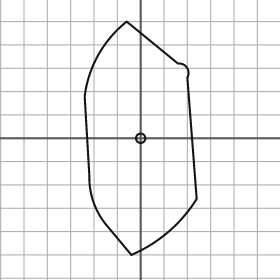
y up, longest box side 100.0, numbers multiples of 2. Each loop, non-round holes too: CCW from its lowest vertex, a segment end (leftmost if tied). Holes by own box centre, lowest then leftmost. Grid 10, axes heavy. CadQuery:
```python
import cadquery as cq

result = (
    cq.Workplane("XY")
    .moveTo(-4.0, -50.0)
    .threePointArc((12.0, -40.0), (24.0, -26.0))
    .lineTo(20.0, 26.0)
    .threePointArc((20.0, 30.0), (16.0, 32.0))
    .lineTo(-6.0, 50.0)
    .threePointArc((-18.0, 36.0), (-24.0, 18.0))
    .lineTo(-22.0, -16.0)
    .threePointArc((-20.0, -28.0), (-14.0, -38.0))
    .close()
    .moveTo(0.0, 0.0)
    .circle(2.0)
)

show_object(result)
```